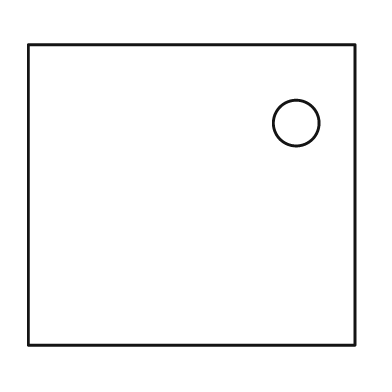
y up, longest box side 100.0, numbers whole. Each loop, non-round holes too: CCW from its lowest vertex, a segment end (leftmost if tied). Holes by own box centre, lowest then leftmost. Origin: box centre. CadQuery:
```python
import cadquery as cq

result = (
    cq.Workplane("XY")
    .moveTo(-50.0, -46.0)
    .lineTo(50.0, -46.0)
    .lineTo(50.0, 46.0)
    .lineTo(-50.0, 46.0)
    .close()
    .moveTo(32.0, 22.0)
    .circle(7.0)
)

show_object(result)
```